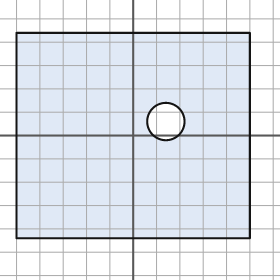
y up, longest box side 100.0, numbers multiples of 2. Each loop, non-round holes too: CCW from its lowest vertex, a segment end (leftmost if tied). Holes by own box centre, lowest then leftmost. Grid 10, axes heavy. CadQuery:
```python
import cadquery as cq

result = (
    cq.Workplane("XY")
    .moveTo(-50.0, -44.0)
    .lineTo(50.0, -44.0)
    .lineTo(50.0, 44.0)
    .lineTo(-50.0, 44.0)
    .close()
    .moveTo(14.0, 6.0)
    .circle(8.0)
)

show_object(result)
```